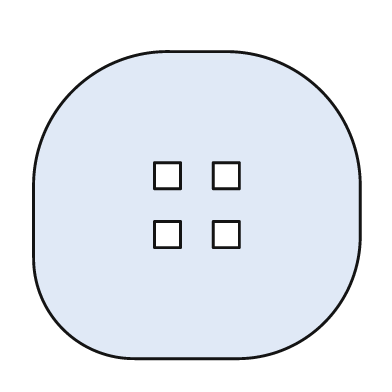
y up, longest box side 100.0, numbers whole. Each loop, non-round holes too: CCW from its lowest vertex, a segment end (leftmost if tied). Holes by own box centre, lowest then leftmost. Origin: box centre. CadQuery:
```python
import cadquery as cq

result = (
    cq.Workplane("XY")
    .moveTo(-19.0, -47.0)
    .lineTo(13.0, -47.0)
    .threePointArc((39.0, -36.0), (50.0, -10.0))
    .lineTo(50.0, 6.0)
    .threePointArc((38.0, 35.0), (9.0, 47.0))
    .lineTo(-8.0, 47.0)
    .threePointArc((-38.0, 35.0), (-50.0, 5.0))
    .lineTo(-50.0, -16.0)
    .threePointArc((-41.0, -38.0), (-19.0, -47.0))
    .close()
    .moveTo(-13.0, -13.0)
    .lineTo(-5.0, -13.0)
    .lineTo(-5.0, -5.0)
    .lineTo(-13.0, -5.0)
    .close()
    .moveTo(5.0, -13.0)
    .lineTo(13.0, -13.0)
    .lineTo(13.0, -5.0)
    .lineTo(5.0, -5.0)
    .close()
    .moveTo(-13.0, 5.0)
    .lineTo(-5.0, 5.0)
    .lineTo(-5.0, 13.0)
    .lineTo(-13.0, 13.0)
    .close()
    .moveTo(5.0, 5.0)
    .lineTo(13.0, 5.0)
    .lineTo(13.0, 13.0)
    .lineTo(5.0, 13.0)
    .close()
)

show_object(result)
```